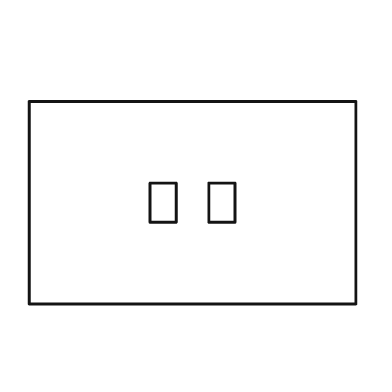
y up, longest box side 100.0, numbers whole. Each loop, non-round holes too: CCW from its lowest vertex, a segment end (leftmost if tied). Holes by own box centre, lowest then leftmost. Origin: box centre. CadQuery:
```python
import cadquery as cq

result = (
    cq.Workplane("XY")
    .moveTo(-50.0, -31.0)
    .lineTo(50.0, -31.0)
    .lineTo(50.0, 31.0)
    .lineTo(-50.0, 31.0)
    .close()
    .moveTo(-13.0, -6.0)
    .lineTo(-5.0, -6.0)
    .lineTo(-5.0, 6.0)
    .lineTo(-13.0, 6.0)
    .close()
    .moveTo(5.0, -6.0)
    .lineTo(13.0, -6.0)
    .lineTo(13.0, 6.0)
    .lineTo(5.0, 6.0)
    .close()
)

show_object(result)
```